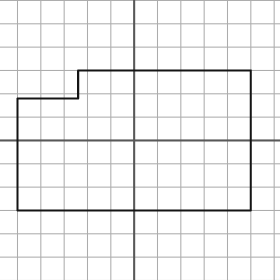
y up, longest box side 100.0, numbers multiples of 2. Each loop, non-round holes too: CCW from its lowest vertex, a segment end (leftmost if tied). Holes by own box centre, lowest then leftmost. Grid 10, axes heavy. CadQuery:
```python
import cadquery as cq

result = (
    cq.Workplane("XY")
    .moveTo(-50.0, -30.0)
    .lineTo(50.0, -30.0)
    .lineTo(50.0, 30.0)
    .lineTo(-24.0, 30.0)
    .lineTo(-24.0, 18.0)
    .lineTo(-50.0, 18.0)
    .close()
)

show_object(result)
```